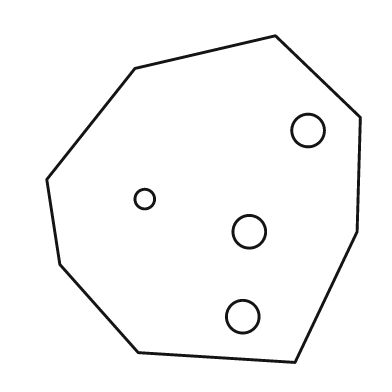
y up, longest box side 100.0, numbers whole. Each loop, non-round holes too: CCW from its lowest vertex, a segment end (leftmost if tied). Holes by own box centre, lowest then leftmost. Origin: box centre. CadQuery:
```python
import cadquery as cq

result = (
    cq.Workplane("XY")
    .moveTo(28.0, -50.0)
    .lineTo(47.0, -10.0)
    .lineTo(48.0, 25.0)
    .lineTo(22.0, 50.0)
    .lineTo(-21.0, 40.0)
    .lineTo(-48.0, 6.0)
    .lineTo(-44.0, -20.0)
    .lineTo(-20.0, -47.0)
    .close()
    .moveTo(12.0, -36.0)
    .circle(5.0)
    .moveTo(14.0, -10.0)
    .circle(5.0)
    .moveTo(-18.0, 0.0)
    .circle(3.0)
    .moveTo(32.0, 21.0)
    .circle(5.0)
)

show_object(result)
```